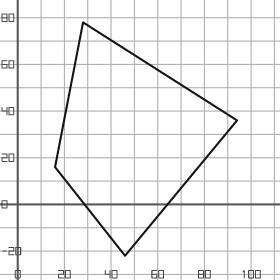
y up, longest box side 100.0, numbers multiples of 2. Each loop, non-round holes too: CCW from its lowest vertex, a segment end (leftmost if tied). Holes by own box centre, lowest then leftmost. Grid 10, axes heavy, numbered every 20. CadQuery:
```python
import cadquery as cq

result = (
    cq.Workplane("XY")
    .moveTo(46.0, -22.0)
    .lineTo(94.0, 36.0)
    .lineTo(28.0, 78.0)
    .lineTo(16.0, 16.0)
    .close()
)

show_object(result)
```